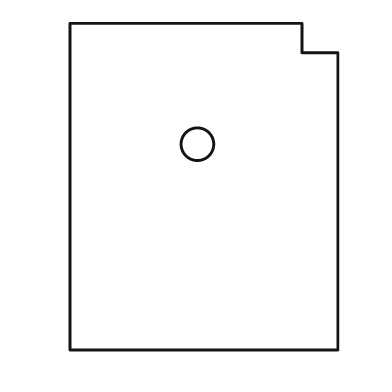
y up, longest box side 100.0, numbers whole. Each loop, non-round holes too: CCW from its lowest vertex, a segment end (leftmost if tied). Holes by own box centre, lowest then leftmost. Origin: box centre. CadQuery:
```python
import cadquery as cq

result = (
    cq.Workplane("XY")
    .moveTo(-41.0, -50.0)
    .lineTo(41.0, -50.0)
    .lineTo(41.0, 41.0)
    .lineTo(30.0, 41.0)
    .lineTo(30.0, 50.0)
    .lineTo(-41.0, 50.0)
    .close()
    .moveTo(-2.0, 13.0)
    .circle(5.0)
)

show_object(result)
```